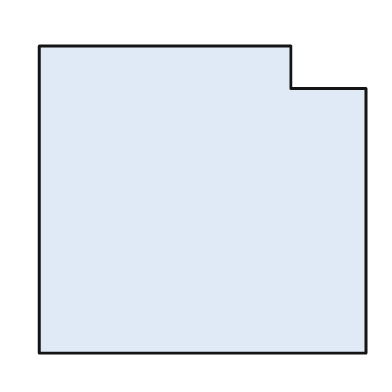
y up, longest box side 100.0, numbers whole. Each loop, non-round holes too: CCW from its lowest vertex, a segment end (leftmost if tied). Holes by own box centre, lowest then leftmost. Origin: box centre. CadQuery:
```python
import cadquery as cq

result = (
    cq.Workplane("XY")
    .moveTo(-50.0, -47.0)
    .lineTo(50.0, -47.0)
    .lineTo(50.0, 34.0)
    .lineTo(27.0, 34.0)
    .lineTo(27.0, 47.0)
    .lineTo(-50.0, 47.0)
    .close()
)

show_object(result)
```